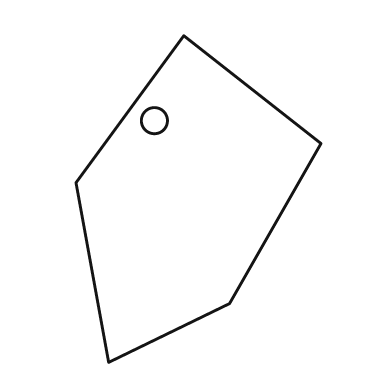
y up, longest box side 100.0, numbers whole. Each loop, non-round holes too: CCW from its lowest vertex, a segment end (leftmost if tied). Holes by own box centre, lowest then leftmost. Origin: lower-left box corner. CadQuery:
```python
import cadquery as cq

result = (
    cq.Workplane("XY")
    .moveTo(10.0, 0.0)
    .lineTo(47.0, 18.0)
    .lineTo(75.0, 67.0)
    .lineTo(33.0, 100.0)
    .lineTo(0.0, 55.0)
    .close()
    .moveTo(24.0, 74.0)
    .circle(4.0)
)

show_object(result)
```